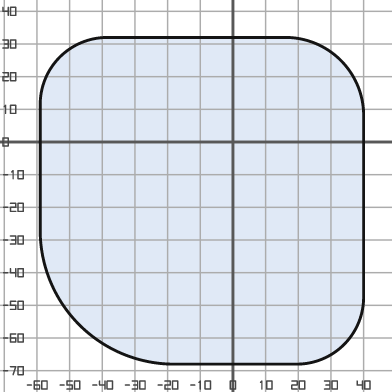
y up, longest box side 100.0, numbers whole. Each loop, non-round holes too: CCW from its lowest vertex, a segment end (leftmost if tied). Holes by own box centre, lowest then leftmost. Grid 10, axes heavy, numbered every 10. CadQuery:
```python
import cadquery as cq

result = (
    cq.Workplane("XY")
    .moveTo(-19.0, -68.0)
    .lineTo(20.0, -68.0)
    .threePointArc((34.0, -62.0), (40.0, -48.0))
    .lineTo(40.0, 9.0)
    .threePointArc((33.0, 25.0), (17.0, 32.0))
    .lineTo(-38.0, 32.0)
    .threePointArc((-53.0, 26.0), (-59.0, 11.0))
    .lineTo(-59.0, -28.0)
    .threePointArc((-47.0, -56.0), (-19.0, -68.0))
    .close()
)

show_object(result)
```